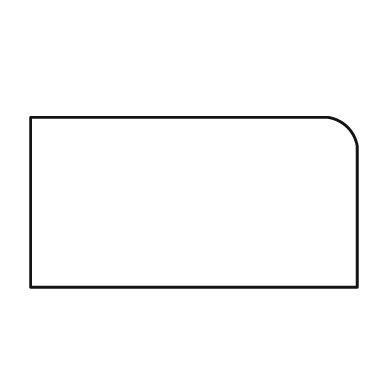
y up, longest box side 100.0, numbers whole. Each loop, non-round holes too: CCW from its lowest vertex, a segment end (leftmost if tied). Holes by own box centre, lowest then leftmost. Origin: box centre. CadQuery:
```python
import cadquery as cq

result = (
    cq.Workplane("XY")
    .moveTo(-50.0, -26.0)
    .lineTo(50.0, -26.0)
    .lineTo(50.0, 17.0)
    .threePointArc((47.0, 23.0), (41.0, 26.0))
    .lineTo(-50.0, 26.0)
    .close()
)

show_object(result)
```